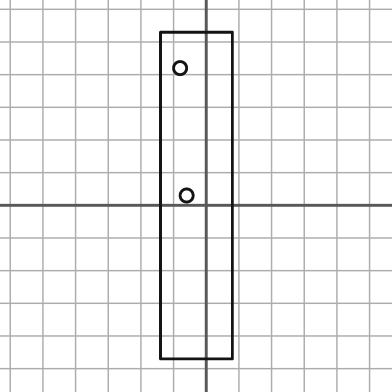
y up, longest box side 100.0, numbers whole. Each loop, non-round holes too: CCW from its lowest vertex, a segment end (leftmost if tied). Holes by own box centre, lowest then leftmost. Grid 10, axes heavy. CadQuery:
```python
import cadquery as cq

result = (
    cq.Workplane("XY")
    .moveTo(-14.0, -47.0)
    .lineTo(8.0, -47.0)
    .lineTo(8.0, 53.0)
    .lineTo(-14.0, 53.0)
    .close()
    .moveTo(-6.0, 3.0)
    .circle(2.0)
    .moveTo(-8.0, 42.0)
    .circle(2.0)
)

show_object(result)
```